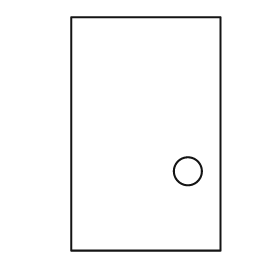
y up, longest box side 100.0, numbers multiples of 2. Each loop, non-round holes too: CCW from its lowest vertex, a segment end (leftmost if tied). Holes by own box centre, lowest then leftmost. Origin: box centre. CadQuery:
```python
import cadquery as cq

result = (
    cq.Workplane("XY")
    .moveTo(-32.0, -50.0)
    .lineTo(32.0, -50.0)
    .lineTo(32.0, 50.0)
    .lineTo(-32.0, 50.0)
    .close()
    .moveTo(18.0, -16.0)
    .circle(6.0)
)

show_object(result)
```